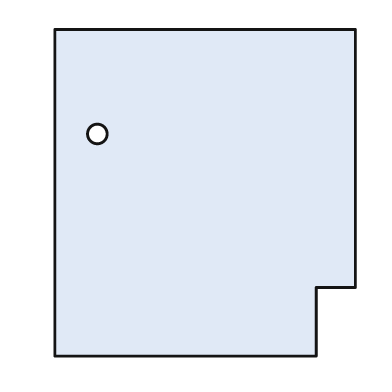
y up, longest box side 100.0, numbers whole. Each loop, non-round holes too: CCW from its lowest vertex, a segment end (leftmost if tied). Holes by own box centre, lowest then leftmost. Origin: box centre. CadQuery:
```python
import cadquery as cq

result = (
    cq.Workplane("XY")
    .moveTo(-46.0, -50.0)
    .lineTo(34.0, -50.0)
    .lineTo(34.0, -29.0)
    .lineTo(46.0, -29.0)
    .lineTo(46.0, 50.0)
    .lineTo(-46.0, 50.0)
    .close()
    .moveTo(-33.0, 18.0)
    .circle(3.0)
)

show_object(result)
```